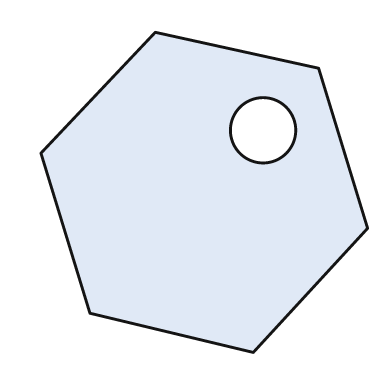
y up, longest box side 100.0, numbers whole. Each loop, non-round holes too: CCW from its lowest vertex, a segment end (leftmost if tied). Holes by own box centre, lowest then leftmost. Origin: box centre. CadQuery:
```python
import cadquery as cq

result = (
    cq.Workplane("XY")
    .moveTo(15.0, -49.0)
    .lineTo(50.0, -11.0)
    .lineTo(35.0, 38.0)
    .lineTo(-15.0, 49.0)
    .lineTo(-50.0, 12.0)
    .lineTo(-35.0, -37.0)
    .close()
    .moveTo(18.0, 19.0)
    .circle(10.0)
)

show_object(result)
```